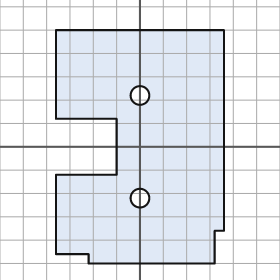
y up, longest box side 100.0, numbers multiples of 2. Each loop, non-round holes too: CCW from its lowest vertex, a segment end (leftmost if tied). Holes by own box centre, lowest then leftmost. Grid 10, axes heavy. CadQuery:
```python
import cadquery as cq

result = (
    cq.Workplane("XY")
    .moveTo(-22.0, -50.0)
    .lineTo(32.0, -50.0)
    .lineTo(32.0, -36.0)
    .lineTo(36.0, -36.0)
    .lineTo(36.0, 50.0)
    .lineTo(-36.0, 50.0)
    .lineTo(-36.0, 12.0)
    .lineTo(-10.0, 12.0)
    .lineTo(-10.0, -12.0)
    .lineTo(-36.0, -12.0)
    .lineTo(-36.0, -46.0)
    .lineTo(-22.0, -46.0)
    .close()
    .moveTo(0.0, -22.0)
    .circle(4.0)
    .moveTo(0.0, 22.0)
    .circle(4.0)
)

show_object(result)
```